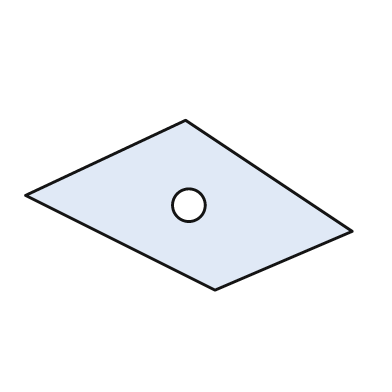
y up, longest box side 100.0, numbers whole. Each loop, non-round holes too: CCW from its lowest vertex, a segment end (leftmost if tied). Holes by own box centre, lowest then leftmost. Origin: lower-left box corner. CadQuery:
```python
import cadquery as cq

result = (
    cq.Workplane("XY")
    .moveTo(58.0, 0.0)
    .lineTo(100.0, 18.0)
    .lineTo(49.0, 52.0)
    .lineTo(0.0, 29.0)
    .close()
    .moveTo(50.0, 26.0)
    .circle(5.0)
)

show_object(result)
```